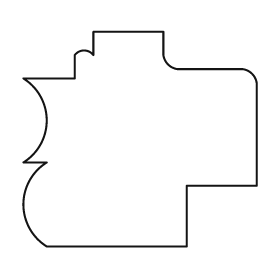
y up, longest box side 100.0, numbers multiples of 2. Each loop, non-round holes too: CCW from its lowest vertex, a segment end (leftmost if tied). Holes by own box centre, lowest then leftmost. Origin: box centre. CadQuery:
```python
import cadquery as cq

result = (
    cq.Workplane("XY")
    .moveTo(-40.0, -46.0)
    .lineTo(20.0, -46.0)
    .lineTo(20.0, -20.0)
    .lineTo(50.0, -20.0)
    .lineTo(50.0, 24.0)
    .threePointArc((48.0, 28.0), (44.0, 30.0))
    .lineTo(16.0, 30.0)
    .threePointArc((12.0, 32.0), (10.0, 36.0))
    .lineTo(10.0, 46.0)
    .lineTo(-20.0, 46.0)
    .lineTo(-20.0, 36.0)
    .threePointArc((-24.0, 38.0), (-28.0, 36.0))
    .lineTo(-28.0, 26.0)
    .lineTo(-50.0, 26.0)
    .threePointArc((-40.0, 8.0), (-50.0, -10.0))
    .lineTo(-40.0, -10.0)
    .threePointArc((-50.0, -28.0), (-40.0, -46.0))
    .close()
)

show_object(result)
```